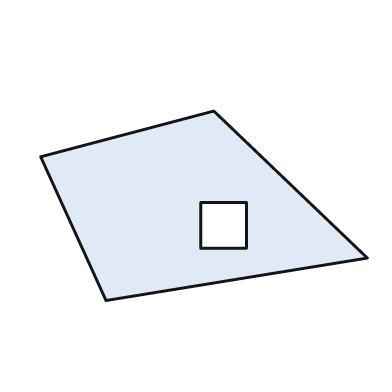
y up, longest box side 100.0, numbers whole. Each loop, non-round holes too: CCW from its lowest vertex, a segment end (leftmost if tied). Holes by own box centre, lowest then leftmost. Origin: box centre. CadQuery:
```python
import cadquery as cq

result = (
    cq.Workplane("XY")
    .moveTo(-30.0, -29.0)
    .lineTo(50.0, -16.0)
    .lineTo(3.0, 29.0)
    .lineTo(-50.0, 15.0)
    .close()
    .moveTo(-1.0, -13.0)
    .lineTo(13.0, -13.0)
    .lineTo(13.0, 1.0)
    .lineTo(-1.0, 1.0)
    .close()
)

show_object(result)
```